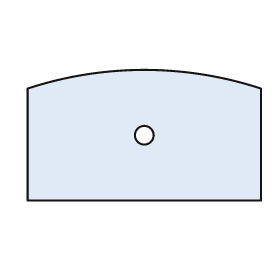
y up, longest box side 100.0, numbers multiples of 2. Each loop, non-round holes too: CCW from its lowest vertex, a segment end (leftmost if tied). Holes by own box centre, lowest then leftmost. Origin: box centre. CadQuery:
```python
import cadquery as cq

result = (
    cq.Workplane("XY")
    .moveTo(-50.0, -28.0)
    .lineTo(50.0, -28.0)
    .lineTo(50.0, 20.0)
    .threePointArc((0.0, 28.0), (-50.0, 20.0))
    .close()
    .moveTo(0.0, 0.0)
    .circle(4.0)
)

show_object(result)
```